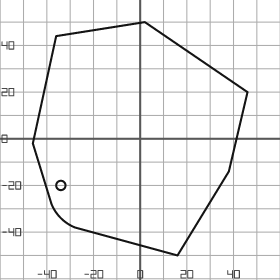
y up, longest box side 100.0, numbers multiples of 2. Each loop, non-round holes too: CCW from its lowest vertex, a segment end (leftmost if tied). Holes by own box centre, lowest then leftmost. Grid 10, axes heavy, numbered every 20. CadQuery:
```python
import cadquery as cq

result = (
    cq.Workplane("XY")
    .moveTo(16.0, -50.0)
    .lineTo(38.0, -14.0)
    .lineTo(46.0, 20.0)
    .lineTo(2.0, 50.0)
    .lineTo(-36.0, 44.0)
    .lineTo(-46.0, -2.0)
    .lineTo(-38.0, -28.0)
    .threePointArc((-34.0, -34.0), (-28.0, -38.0))
    .close()
    .moveTo(-34.0, -20.0)
    .circle(2.0)
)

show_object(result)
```